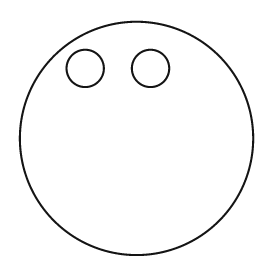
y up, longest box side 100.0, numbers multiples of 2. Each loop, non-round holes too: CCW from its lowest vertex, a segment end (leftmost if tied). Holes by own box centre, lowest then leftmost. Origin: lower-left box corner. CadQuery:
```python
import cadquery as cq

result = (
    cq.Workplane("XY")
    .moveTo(50.0, 50.0)
    .circle(50.0)
    .moveTo(28.0, 80.0)
    .circle(8.0)
    .moveTo(56.0, 80.0)
    .circle(8.0)
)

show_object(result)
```